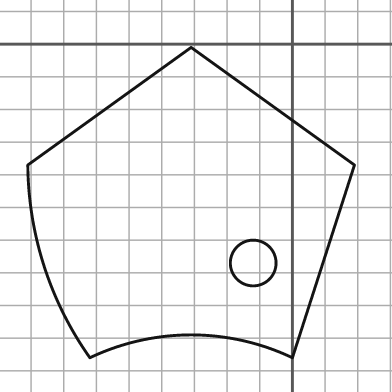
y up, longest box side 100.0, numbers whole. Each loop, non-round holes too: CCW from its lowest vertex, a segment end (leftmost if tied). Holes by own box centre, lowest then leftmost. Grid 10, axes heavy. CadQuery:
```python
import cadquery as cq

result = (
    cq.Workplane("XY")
    .moveTo(-62.0, -96.0)
    .threePointArc((-31.0, -89.0), (0.0, -96.0))
    .lineTo(19.0, -37.0)
    .lineTo(-31.0, -1.0)
    .lineTo(-81.0, -37.0)
    .threePointArc((-76.0, -68.0), (-62.0, -96.0))
    .close()
    .moveTo(-12.0, -67.0)
    .circle(7.0)
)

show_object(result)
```